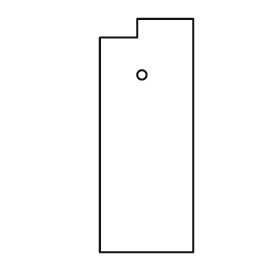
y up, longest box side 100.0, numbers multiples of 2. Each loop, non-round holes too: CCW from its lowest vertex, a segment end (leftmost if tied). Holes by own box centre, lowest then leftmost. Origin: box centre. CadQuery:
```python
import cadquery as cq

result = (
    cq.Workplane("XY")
    .moveTo(-20.0, -50.0)
    .lineTo(20.0, -50.0)
    .lineTo(20.0, 50.0)
    .lineTo(-4.0, 50.0)
    .lineTo(-4.0, 42.0)
    .lineTo(-20.0, 42.0)
    .close()
    .moveTo(-2.0, 26.0)
    .circle(2.0)
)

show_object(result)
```